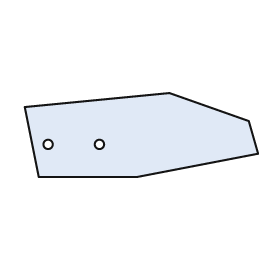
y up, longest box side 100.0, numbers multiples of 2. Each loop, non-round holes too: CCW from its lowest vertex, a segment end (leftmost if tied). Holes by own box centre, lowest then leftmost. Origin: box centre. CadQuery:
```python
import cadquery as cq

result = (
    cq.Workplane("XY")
    .moveTo(-44.0, -18.0)
    .lineTo(-2.0, -18.0)
    .lineTo(50.0, -8.0)
    .lineTo(46.0, 6.0)
    .lineTo(12.0, 18.0)
    .lineTo(-50.0, 12.0)
    .close()
    .moveTo(-40.0, -4.0)
    .circle(2.0)
    .moveTo(-18.0, -4.0)
    .circle(2.0)
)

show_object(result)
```